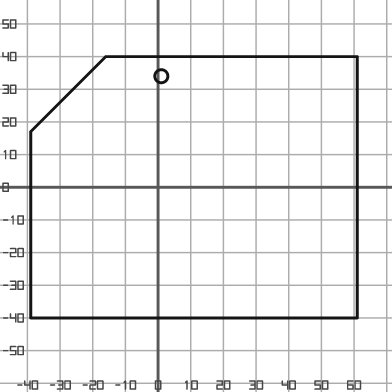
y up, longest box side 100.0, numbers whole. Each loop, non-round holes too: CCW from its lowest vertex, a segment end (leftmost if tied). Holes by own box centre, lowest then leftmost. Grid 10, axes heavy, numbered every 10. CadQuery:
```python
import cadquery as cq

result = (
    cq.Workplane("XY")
    .moveTo(-39.0, -40.0)
    .lineTo(61.0, -40.0)
    .lineTo(61.0, 40.0)
    .lineTo(-16.0, 40.0)
    .lineTo(-39.0, 17.0)
    .close()
    .moveTo(1.0, 34.0)
    .circle(2.0)
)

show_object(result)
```